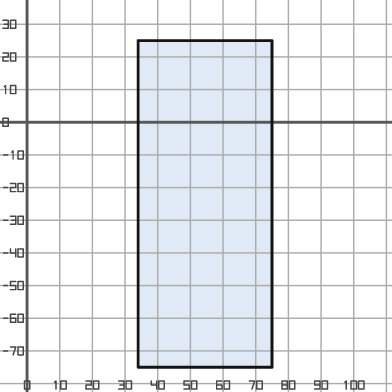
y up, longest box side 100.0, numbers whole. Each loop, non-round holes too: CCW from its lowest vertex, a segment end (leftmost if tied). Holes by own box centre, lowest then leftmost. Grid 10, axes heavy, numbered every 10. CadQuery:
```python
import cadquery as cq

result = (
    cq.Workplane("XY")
    .moveTo(34.0, -75.0)
    .lineTo(75.0, -75.0)
    .lineTo(75.0, 25.0)
    .lineTo(34.0, 25.0)
    .close()
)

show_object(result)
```